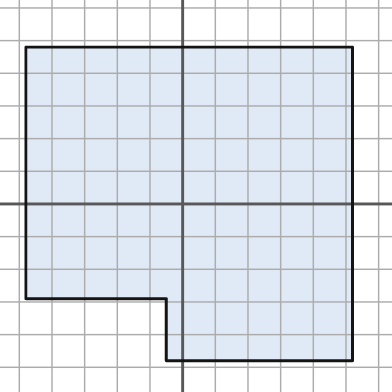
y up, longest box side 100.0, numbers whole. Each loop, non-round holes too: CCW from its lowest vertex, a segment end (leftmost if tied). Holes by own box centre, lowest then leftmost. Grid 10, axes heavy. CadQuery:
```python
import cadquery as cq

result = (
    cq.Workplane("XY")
    .moveTo(-5.0, -48.0)
    .lineTo(52.0, -48.0)
    .lineTo(52.0, 48.0)
    .lineTo(-48.0, 48.0)
    .lineTo(-48.0, -29.0)
    .lineTo(-5.0, -29.0)
    .close()
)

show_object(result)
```